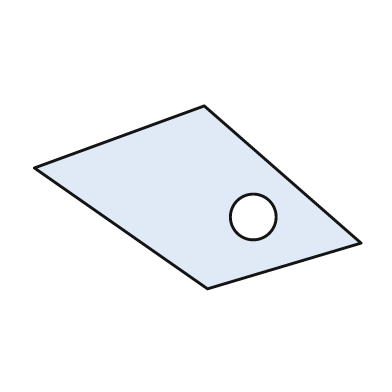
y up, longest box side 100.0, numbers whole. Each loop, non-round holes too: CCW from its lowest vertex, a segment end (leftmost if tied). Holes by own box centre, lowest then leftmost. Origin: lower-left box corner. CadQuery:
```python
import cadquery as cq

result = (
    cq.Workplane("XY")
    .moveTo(53.0, 0.0)
    .lineTo(100.0, 14.0)
    .lineTo(52.0, 56.0)
    .lineTo(0.0, 37.0)
    .close()
    .moveTo(67.0, 22.0)
    .circle(7.0)
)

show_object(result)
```